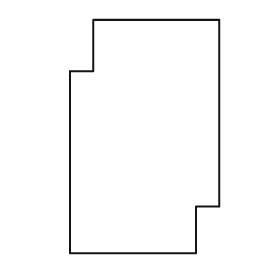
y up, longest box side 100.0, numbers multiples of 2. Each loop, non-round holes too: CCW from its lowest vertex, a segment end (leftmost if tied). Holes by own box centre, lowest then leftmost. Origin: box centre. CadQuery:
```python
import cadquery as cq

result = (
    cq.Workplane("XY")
    .moveTo(-32.0, -50.0)
    .lineTo(22.0, -50.0)
    .lineTo(22.0, -30.0)
    .lineTo(32.0, -30.0)
    .lineTo(32.0, 50.0)
    .lineTo(-22.0, 50.0)
    .lineTo(-22.0, 28.0)
    .lineTo(-32.0, 28.0)
    .close()
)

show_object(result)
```